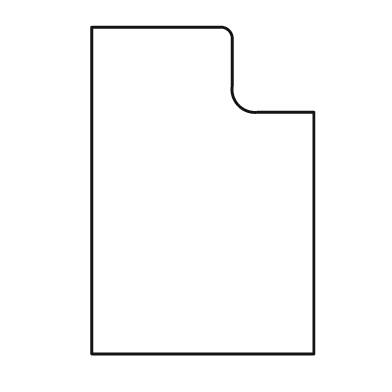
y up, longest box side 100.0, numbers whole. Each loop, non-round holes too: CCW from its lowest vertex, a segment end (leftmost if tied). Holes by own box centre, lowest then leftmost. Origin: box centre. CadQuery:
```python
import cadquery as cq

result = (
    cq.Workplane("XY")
    .moveTo(-34.0, -50.0)
    .lineTo(34.0, -50.0)
    .lineTo(34.0, 24.0)
    .lineTo(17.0, 24.0)
    .threePointArc((11.0, 26.0), (9.0, 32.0))
    .lineTo(9.0, 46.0)
    .threePointArc((8.0, 49.0), (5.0, 50.0))
    .lineTo(-34.0, 50.0)
    .close()
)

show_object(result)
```